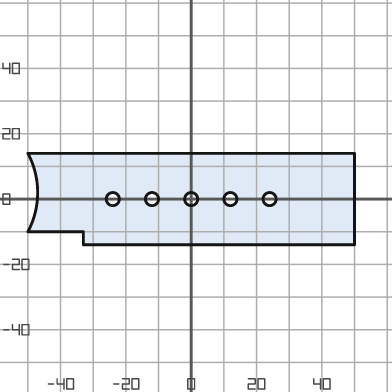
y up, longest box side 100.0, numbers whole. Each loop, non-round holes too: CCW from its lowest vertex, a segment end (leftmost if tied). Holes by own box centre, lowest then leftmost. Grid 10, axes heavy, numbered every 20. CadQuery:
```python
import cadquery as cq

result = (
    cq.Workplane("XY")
    .moveTo(-33.0, -14.0)
    .lineTo(50.0, -14.0)
    .lineTo(50.0, 14.0)
    .lineTo(-50.0, 14.0)
    .threePointArc((-47.0, 2.0), (-50.0, -10.0))
    .lineTo(-33.0, -10.0)
    .close()
    .moveTo(-24.0, 0.0)
    .circle(2.0)
    .moveTo(-12.0, 0.0)
    .circle(2.0)
    .moveTo(0.0, 0.0)
    .circle(2.0)
    .moveTo(12.0, 0.0)
    .circle(2.0)
    .moveTo(24.0, 0.0)
    .circle(2.0)
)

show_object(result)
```